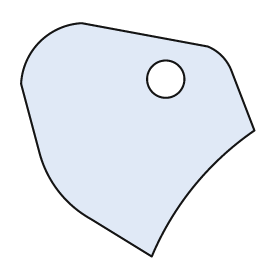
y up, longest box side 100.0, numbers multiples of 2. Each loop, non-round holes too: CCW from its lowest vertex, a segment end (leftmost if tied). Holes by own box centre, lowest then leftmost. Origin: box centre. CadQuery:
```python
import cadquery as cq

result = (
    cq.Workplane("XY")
    .moveTo(6.0, -50.0)
    .threePointArc((24.0, -20.0), (50.0, 4.0))
    .lineTo(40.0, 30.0)
    .threePointArc((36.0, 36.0), (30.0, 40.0))
    .lineTo(-24.0, 50.0)
    .threePointArc((-42.0, 42.0), (-50.0, 24.0))
    .lineTo(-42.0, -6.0)
    .threePointArc((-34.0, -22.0), (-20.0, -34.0))
    .close()
    .moveTo(12.0, 26.0)
    .circle(8.0)
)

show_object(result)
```